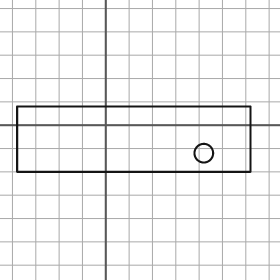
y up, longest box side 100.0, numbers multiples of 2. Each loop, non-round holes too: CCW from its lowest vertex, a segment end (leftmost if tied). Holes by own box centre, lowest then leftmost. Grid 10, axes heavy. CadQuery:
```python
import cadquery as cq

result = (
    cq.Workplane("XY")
    .moveTo(-38.0, -20.0)
    .lineTo(62.0, -20.0)
    .lineTo(62.0, 8.0)
    .lineTo(-38.0, 8.0)
    .close()
    .moveTo(42.0, -12.0)
    .circle(4.0)
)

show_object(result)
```